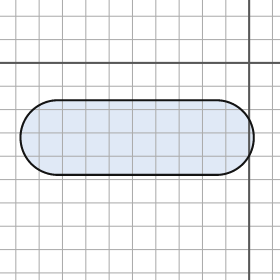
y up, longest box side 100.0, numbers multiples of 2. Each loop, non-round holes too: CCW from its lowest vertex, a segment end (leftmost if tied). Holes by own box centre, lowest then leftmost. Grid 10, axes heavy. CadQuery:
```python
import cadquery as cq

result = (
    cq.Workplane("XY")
    .moveTo(-82.0, -48.0)
    .lineTo(-14.0, -48.0)
    .threePointArc((2.0, -32.0), (-14.0, -16.0))
    .lineTo(-82.0, -16.0)
    .threePointArc((-98.0, -32.0), (-82.0, -48.0))
    .close()
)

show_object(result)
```